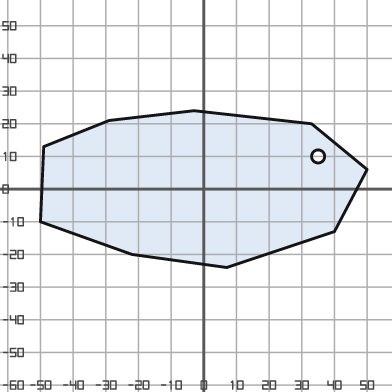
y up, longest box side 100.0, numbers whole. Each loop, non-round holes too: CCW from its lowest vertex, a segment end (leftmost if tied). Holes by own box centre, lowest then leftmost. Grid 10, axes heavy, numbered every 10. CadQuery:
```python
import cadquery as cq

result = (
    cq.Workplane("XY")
    .moveTo(7.0, -24.0)
    .lineTo(40.0, -13.0)
    .lineTo(50.0, 6.0)
    .lineTo(33.0, 20.0)
    .lineTo(-3.0, 24.0)
    .lineTo(-29.0, 21.0)
    .lineTo(-49.0, 13.0)
    .lineTo(-50.0, -10.0)
    .lineTo(-22.0, -20.0)
    .close()
    .moveTo(35.0, 10.0)
    .circle(2.0)
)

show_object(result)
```